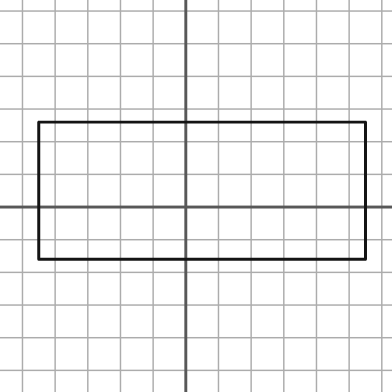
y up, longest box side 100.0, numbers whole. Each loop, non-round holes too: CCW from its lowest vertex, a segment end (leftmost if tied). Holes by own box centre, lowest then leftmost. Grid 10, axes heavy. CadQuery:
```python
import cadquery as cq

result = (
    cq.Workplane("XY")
    .moveTo(-45.0, -16.0)
    .lineTo(55.0, -16.0)
    .lineTo(55.0, 26.0)
    .lineTo(-45.0, 26.0)
    .close()
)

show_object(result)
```